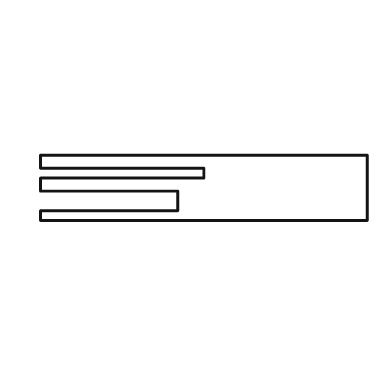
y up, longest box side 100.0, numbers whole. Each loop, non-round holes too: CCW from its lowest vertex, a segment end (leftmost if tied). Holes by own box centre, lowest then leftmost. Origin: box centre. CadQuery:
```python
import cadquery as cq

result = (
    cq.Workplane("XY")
    .moveTo(-50.0, -10.0)
    .lineTo(50.0, -10.0)
    .lineTo(50.0, 10.0)
    .lineTo(-50.0, 10.0)
    .lineTo(-50.0, 6.0)
    .lineTo(0.0, 6.0)
    .lineTo(0.0, 3.0)
    .lineTo(-50.0, 3.0)
    .lineTo(-50.0, -1.0)
    .lineTo(-8.0, -1.0)
    .lineTo(-8.0, -7.0)
    .lineTo(-50.0, -7.0)
    .close()
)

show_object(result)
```